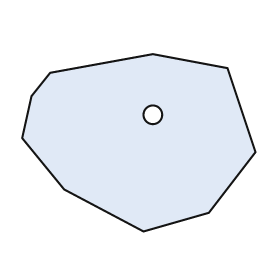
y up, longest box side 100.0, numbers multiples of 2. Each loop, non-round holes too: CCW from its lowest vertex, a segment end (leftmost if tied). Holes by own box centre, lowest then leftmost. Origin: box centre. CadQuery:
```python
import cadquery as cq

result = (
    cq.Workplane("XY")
    .moveTo(2.0, -38.0)
    .lineTo(30.0, -30.0)
    .lineTo(50.0, -4.0)
    .lineTo(38.0, 32.0)
    .lineTo(6.0, 38.0)
    .lineTo(-38.0, 30.0)
    .lineTo(-46.0, 20.0)
    .lineTo(-50.0, 2.0)
    .lineTo(-32.0, -20.0)
    .close()
    .moveTo(6.0, 12.0)
    .circle(4.0)
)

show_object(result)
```